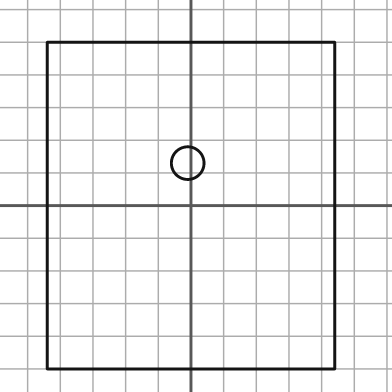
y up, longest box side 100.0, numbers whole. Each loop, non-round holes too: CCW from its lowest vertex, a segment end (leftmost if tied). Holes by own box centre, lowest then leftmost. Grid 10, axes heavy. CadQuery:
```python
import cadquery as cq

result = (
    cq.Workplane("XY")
    .moveTo(-44.0, -50.0)
    .lineTo(44.0, -50.0)
    .lineTo(44.0, 50.0)
    .lineTo(-44.0, 50.0)
    .close()
    .moveTo(-1.0, 13.0)
    .circle(5.0)
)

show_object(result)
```